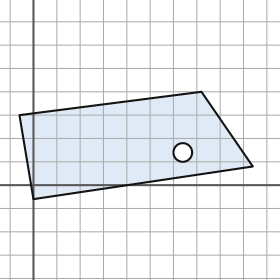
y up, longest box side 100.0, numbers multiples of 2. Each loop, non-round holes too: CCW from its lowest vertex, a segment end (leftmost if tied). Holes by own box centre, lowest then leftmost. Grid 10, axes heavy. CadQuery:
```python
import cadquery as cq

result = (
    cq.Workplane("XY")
    .moveTo(0.0, -6.0)
    .lineTo(94.0, 8.0)
    .lineTo(72.0, 40.0)
    .lineTo(-6.0, 30.0)
    .close()
    .moveTo(64.0, 14.0)
    .circle(4.0)
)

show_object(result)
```